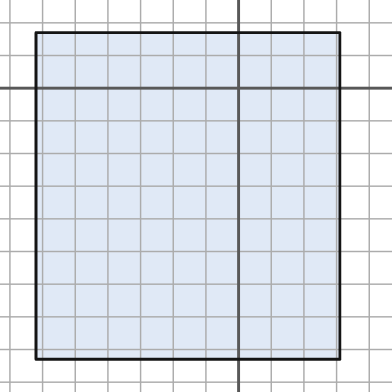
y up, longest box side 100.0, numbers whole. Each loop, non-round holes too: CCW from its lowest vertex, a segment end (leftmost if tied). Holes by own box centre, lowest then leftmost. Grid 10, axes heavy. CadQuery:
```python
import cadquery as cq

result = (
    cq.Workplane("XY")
    .moveTo(-62.0, -83.0)
    .lineTo(31.0, -83.0)
    .lineTo(31.0, 17.0)
    .lineTo(-62.0, 17.0)
    .close()
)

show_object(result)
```